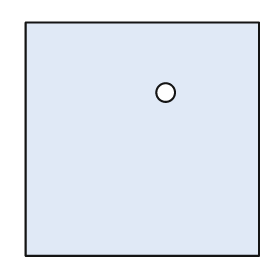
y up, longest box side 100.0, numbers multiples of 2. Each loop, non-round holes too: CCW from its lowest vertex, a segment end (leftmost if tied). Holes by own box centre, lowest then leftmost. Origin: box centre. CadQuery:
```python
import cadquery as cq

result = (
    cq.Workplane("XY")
    .moveTo(-50.0, -50.0)
    .lineTo(50.0, -50.0)
    .lineTo(50.0, 50.0)
    .lineTo(-50.0, 50.0)
    .close()
    .moveTo(10.0, 20.0)
    .circle(4.0)
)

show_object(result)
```